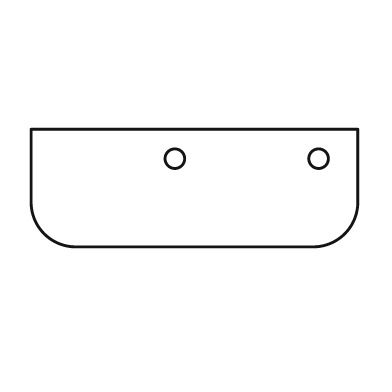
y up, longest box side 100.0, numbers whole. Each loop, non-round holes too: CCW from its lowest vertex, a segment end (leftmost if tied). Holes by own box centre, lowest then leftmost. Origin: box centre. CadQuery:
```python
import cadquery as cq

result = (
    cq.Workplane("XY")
    .moveTo(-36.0, -18.0)
    .lineTo(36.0, -18.0)
    .threePointArc((46.0, -14.0), (50.0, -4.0))
    .lineTo(50.0, 18.0)
    .lineTo(-50.0, 18.0)
    .lineTo(-50.0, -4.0)
    .threePointArc((-46.0, -14.0), (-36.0, -18.0))
    .close()
    .moveTo(-6.0, 9.0)
    .circle(3.0)
    .moveTo(38.0, 9.0)
    .circle(3.0)
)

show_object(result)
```